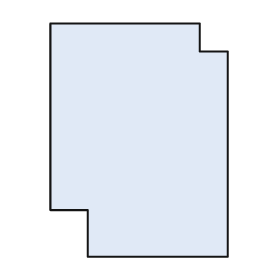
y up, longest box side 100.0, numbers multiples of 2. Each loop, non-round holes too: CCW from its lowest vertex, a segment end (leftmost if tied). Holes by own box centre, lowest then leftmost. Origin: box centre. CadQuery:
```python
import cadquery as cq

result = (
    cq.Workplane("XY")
    .moveTo(-22.0, -50.0)
    .lineTo(38.0, -50.0)
    .lineTo(38.0, 38.0)
    .lineTo(26.0, 38.0)
    .lineTo(26.0, 50.0)
    .lineTo(-38.0, 50.0)
    .lineTo(-38.0, -30.0)
    .lineTo(-22.0, -30.0)
    .close()
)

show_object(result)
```